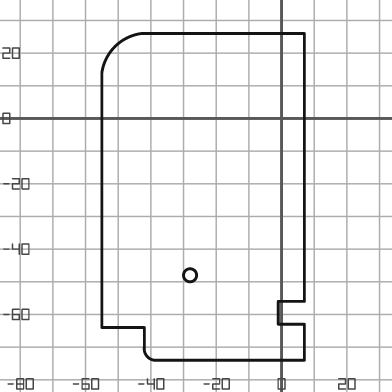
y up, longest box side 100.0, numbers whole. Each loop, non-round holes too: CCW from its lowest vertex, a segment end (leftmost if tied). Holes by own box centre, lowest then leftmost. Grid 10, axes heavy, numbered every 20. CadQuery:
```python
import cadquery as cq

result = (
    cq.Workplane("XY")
    .moveTo(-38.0, -74.0)
    .lineTo(7.0, -74.0)
    .lineTo(7.0, -63.0)
    .lineTo(-1.0, -63.0)
    .lineTo(-1.0, -56.0)
    .lineTo(7.0, -56.0)
    .lineTo(7.0, 26.0)
    .lineTo(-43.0, 26.0)
    .threePointArc((-51.0, 22.0), (-55.0, 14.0))
    .lineTo(-55.0, -64.0)
    .lineTo(-42.0, -64.0)
    .lineTo(-42.0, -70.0)
    .threePointArc((-41.0, -73.0), (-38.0, -74.0))
    .close()
    .moveTo(-28.0, -48.0)
    .circle(2.0)
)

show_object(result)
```